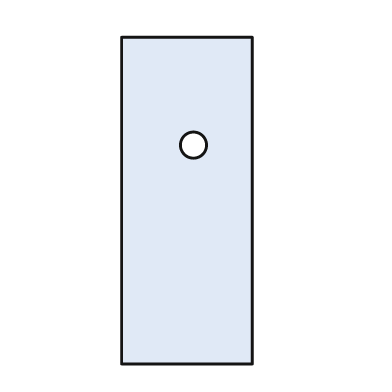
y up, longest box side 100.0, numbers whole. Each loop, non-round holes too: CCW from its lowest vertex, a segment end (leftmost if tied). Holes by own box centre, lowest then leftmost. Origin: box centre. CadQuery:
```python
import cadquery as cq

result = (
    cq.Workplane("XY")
    .moveTo(-20.0, -50.0)
    .lineTo(20.0, -50.0)
    .lineTo(20.0, 50.0)
    .lineTo(-20.0, 50.0)
    .close()
    .moveTo(2.0, 17.0)
    .circle(4.0)
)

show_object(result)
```